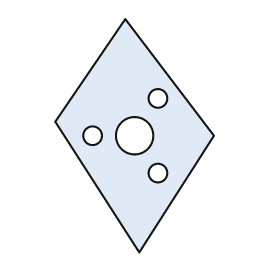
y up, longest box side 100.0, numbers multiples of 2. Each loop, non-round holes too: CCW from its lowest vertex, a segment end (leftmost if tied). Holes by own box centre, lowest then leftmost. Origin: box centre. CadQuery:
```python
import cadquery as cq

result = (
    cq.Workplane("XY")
    .moveTo(2.0, -50.0)
    .lineTo(34.0, 0.0)
    .lineTo(-4.0, 50.0)
    .lineTo(-34.0, 6.0)
    .close()
    .moveTo(10.0, -16.0)
    .circle(4.0)
    .moveTo(-18.0, 0.0)
    .circle(4.0)
    .moveTo(0.0, 0.0)
    .circle(8.0)
    .moveTo(10.0, 16.0)
    .circle(4.0)
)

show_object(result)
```